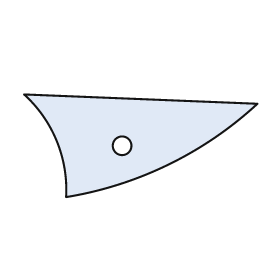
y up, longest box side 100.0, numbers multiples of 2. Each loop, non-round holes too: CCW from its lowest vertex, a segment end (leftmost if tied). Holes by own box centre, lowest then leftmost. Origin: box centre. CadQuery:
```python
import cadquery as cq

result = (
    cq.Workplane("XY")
    .moveTo(-32.0, -22.0)
    .threePointArc((12.0, -8.0), (50.0, 18.0))
    .lineTo(-50.0, 22.0)
    .threePointArc((-36.0, 2.0), (-32.0, -22.0))
    .close()
    .moveTo(-8.0, 0.0)
    .circle(4.0)
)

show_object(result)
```